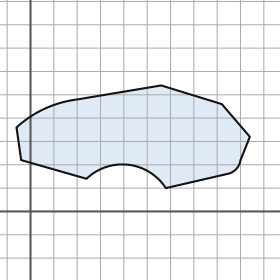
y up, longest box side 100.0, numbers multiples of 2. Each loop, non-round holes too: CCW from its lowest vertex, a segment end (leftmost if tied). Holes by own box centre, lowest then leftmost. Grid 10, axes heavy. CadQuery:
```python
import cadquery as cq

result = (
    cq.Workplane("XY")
    .moveTo(58.0, 10.0)
    .lineTo(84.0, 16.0)
    .threePointArc((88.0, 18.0), (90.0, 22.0))
    .lineTo(94.0, 32.0)
    .lineTo(82.0, 46.0)
    .lineTo(56.0, 54.0)
    .lineTo(20.0, 48.0)
    .threePointArc((6.0, 44.0), (-6.0, 36.0))
    .lineTo(-4.0, 22.0)
    .lineTo(24.0, 14.0)
    .threePointArc((42.0, 20.0), (58.0, 10.0))
    .close()
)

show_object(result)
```